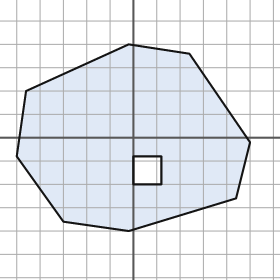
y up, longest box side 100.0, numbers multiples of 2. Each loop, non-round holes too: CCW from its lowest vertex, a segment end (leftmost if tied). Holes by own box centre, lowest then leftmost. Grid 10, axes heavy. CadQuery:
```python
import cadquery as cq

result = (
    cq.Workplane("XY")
    .moveTo(-2.0, -40.0)
    .lineTo(44.0, -26.0)
    .lineTo(50.0, -2.0)
    .lineTo(24.0, 36.0)
    .lineTo(-2.0, 40.0)
    .lineTo(-46.0, 20.0)
    .lineTo(-50.0, -8.0)
    .lineTo(-30.0, -36.0)
    .close()
    .moveTo(0.0, -20.0)
    .lineTo(12.0, -20.0)
    .lineTo(12.0, -8.0)
    .lineTo(0.0, -8.0)
    .close()
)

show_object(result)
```